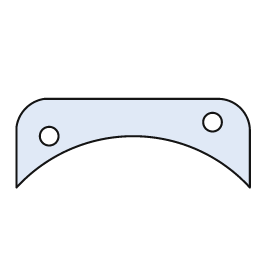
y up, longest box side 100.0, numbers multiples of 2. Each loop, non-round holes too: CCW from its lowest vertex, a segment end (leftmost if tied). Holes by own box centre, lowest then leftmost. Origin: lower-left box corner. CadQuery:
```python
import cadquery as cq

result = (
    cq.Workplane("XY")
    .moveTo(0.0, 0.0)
    .threePointArc((50.0, 22.0), (100.0, 0.0))
    .lineTo(100.0, 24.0)
    .threePointArc((96.0, 34.0), (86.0, 38.0))
    .lineTo(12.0, 38.0)
    .threePointArc((4.0, 34.0), (0.0, 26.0))
    .close()
    .moveTo(14.0, 22.0)
    .circle(4.0)
    .moveTo(84.0, 28.0)
    .circle(4.0)
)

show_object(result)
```